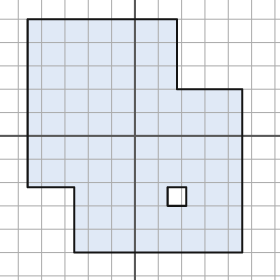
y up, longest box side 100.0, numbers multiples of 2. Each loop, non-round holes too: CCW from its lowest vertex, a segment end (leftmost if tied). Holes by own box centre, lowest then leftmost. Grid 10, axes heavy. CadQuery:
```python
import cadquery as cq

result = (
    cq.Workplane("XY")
    .moveTo(-26.0, -50.0)
    .lineTo(46.0, -50.0)
    .lineTo(46.0, 20.0)
    .lineTo(18.0, 20.0)
    .lineTo(18.0, 50.0)
    .lineTo(-46.0, 50.0)
    .lineTo(-46.0, -22.0)
    .lineTo(-26.0, -22.0)
    .close()
    .moveTo(14.0, -30.0)
    .lineTo(22.0, -30.0)
    .lineTo(22.0, -22.0)
    .lineTo(14.0, -22.0)
    .close()
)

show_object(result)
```